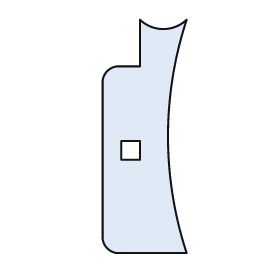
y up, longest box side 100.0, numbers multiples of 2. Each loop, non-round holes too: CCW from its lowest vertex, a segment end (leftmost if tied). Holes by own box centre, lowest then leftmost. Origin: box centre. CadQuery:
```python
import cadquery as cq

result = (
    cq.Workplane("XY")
    .moveTo(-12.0, -50.0)
    .lineTo(18.0, -50.0)
    .threePointArc((10.0, 0.0), (18.0, 50.0))
    .threePointArc((8.0, 46.0), (-2.0, 50.0))
    .lineTo(-2.0, 30.0)
    .lineTo(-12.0, 30.0)
    .threePointArc((-16.0, 28.0), (-18.0, 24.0))
    .lineTo(-18.0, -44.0)
    .threePointArc((-16.0, -48.0), (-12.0, -50.0))
    .close()
    .moveTo(-10.0, -10.0)
    .lineTo(-2.0, -10.0)
    .lineTo(-2.0, -2.0)
    .lineTo(-10.0, -2.0)
    .close()
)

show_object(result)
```